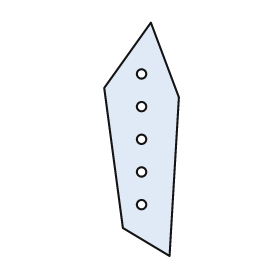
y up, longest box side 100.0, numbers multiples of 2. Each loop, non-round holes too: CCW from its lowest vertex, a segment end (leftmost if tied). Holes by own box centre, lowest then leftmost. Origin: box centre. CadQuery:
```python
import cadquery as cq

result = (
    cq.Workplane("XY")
    .moveTo(12.0, -50.0)
    .lineTo(16.0, 18.0)
    .lineTo(4.0, 50.0)
    .lineTo(-16.0, 22.0)
    .lineTo(-8.0, -38.0)
    .close()
    .moveTo(0.0, -28.0)
    .circle(2.0)
    .moveTo(0.0, -14.0)
    .circle(2.0)
    .moveTo(0.0, 0.0)
    .circle(2.0)
    .moveTo(0.0, 14.0)
    .circle(2.0)
    .moveTo(0.0, 28.0)
    .circle(2.0)
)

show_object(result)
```